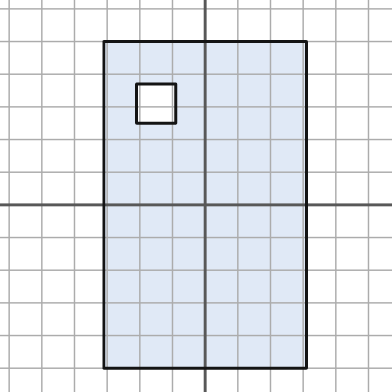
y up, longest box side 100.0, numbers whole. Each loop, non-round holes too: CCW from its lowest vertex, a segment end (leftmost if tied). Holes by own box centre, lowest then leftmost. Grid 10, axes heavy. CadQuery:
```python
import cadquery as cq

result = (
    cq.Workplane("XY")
    .moveTo(-31.0, -50.0)
    .lineTo(31.0, -50.0)
    .lineTo(31.0, 50.0)
    .lineTo(-31.0, 50.0)
    .close()
    .moveTo(-21.0, 25.0)
    .lineTo(-9.0, 25.0)
    .lineTo(-9.0, 37.0)
    .lineTo(-21.0, 37.0)
    .close()
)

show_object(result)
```